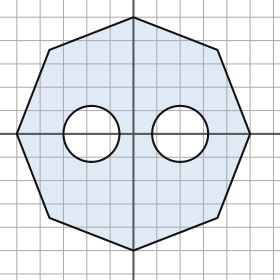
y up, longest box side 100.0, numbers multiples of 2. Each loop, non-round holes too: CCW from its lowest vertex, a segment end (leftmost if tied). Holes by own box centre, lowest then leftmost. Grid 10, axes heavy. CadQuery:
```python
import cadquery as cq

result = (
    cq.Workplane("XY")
    .moveTo(0.0, -50.0)
    .lineTo(36.0, -36.0)
    .lineTo(50.0, 0.0)
    .lineTo(36.0, 36.0)
    .lineTo(0.0, 50.0)
    .lineTo(-36.0, 36.0)
    .lineTo(-50.0, 0.0)
    .lineTo(-36.0, -36.0)
    .close()
    .moveTo(-18.0, 0.0)
    .circle(12.0)
    .moveTo(20.0, 0.0)
    .circle(12.0)
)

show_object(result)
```